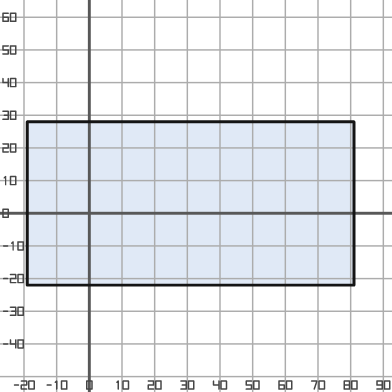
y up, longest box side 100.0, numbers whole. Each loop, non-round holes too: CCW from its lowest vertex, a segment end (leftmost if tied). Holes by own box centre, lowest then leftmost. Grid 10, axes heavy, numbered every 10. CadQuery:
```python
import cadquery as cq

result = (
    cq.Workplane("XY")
    .moveTo(-19.0, -22.0)
    .lineTo(81.0, -22.0)
    .lineTo(81.0, 28.0)
    .lineTo(-19.0, 28.0)
    .close()
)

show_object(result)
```